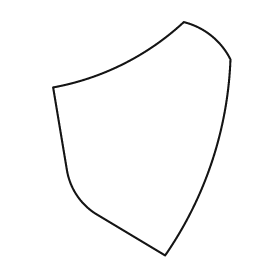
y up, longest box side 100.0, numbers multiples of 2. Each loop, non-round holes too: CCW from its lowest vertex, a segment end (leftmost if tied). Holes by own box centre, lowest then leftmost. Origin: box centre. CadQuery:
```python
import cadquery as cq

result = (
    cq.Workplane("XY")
    .moveTo(10.0, -50.0)
    .threePointArc((30.0, -10.0), (38.0, 34.0))
    .threePointArc((30.0, 44.0), (18.0, 50.0))
    .threePointArc((-8.0, 32.0), (-38.0, 22.0))
    .lineTo(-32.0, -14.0)
    .threePointArc((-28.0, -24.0), (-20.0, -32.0))
    .close()
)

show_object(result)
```